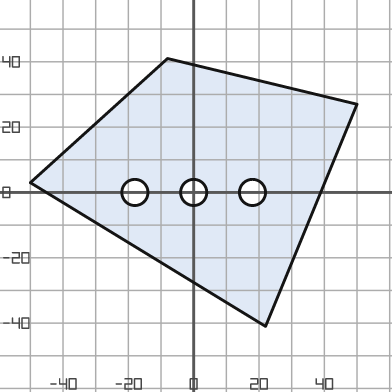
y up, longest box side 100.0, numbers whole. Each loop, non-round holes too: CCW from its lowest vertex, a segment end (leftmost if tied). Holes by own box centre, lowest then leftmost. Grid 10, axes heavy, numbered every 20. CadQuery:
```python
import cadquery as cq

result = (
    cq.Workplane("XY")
    .moveTo(22.0, -41.0)
    .lineTo(50.0, 27.0)
    .lineTo(-8.0, 41.0)
    .lineTo(-50.0, 3.0)
    .close()
    .moveTo(-18.0, 0.0)
    .circle(4.0)
    .moveTo(0.0, 0.0)
    .circle(4.0)
    .moveTo(18.0, 0.0)
    .circle(4.0)
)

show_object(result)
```